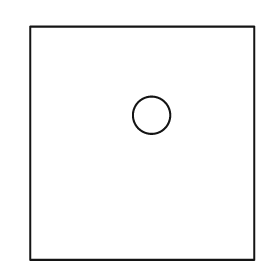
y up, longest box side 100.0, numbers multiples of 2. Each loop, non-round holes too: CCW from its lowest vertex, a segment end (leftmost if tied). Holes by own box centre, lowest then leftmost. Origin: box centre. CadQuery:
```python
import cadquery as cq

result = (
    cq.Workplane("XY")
    .moveTo(-48.0, -50.0)
    .lineTo(48.0, -50.0)
    .lineTo(48.0, 50.0)
    .lineTo(-48.0, 50.0)
    .close()
    .moveTo(4.0, 12.0)
    .circle(8.0)
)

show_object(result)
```